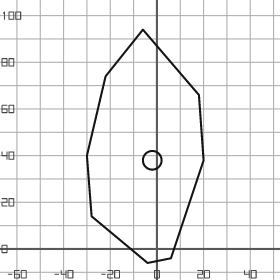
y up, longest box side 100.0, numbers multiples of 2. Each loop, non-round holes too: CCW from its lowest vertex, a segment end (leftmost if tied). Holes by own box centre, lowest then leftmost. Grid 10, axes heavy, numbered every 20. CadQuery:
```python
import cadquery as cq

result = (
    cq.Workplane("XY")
    .moveTo(-4.0, -6.0)
    .lineTo(6.0, -4.0)
    .lineTo(20.0, 38.0)
    .lineTo(18.0, 66.0)
    .lineTo(-6.0, 94.0)
    .lineTo(-22.0, 74.0)
    .lineTo(-30.0, 40.0)
    .lineTo(-28.0, 14.0)
    .close()
    .moveTo(-2.0, 38.0)
    .circle(4.0)
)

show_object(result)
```